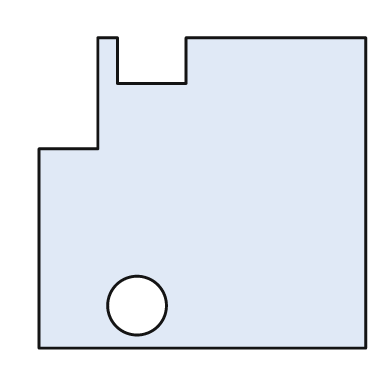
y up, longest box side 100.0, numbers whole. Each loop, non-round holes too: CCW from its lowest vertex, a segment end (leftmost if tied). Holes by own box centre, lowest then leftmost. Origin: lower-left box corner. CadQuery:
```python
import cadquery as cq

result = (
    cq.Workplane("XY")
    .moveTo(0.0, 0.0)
    .lineTo(100.0, 0.0)
    .lineTo(100.0, 95.0)
    .lineTo(45.0, 95.0)
    .lineTo(45.0, 81.0)
    .lineTo(24.0, 81.0)
    .lineTo(24.0, 95.0)
    .lineTo(18.0, 95.0)
    .lineTo(18.0, 61.0)
    .lineTo(0.0, 61.0)
    .close()
    .moveTo(30.0, 13.0)
    .circle(9.0)
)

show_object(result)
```